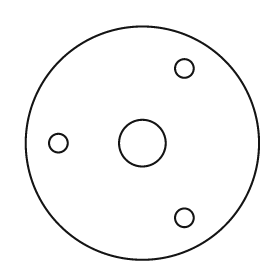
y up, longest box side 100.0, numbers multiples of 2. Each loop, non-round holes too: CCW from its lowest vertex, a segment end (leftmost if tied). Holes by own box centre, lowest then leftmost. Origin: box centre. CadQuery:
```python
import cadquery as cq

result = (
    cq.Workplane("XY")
    .moveTo(0.0, 0.0)
    .circle(50.0)
    .moveTo(18.0, -32.0)
    .circle(4.0)
    .moveTo(-36.0, 0.0)
    .circle(4.0)
    .moveTo(0.0, 0.0)
    .circle(10.0)
    .moveTo(18.0, 32.0)
    .circle(4.0)
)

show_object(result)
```